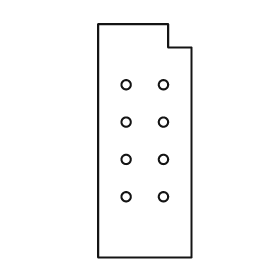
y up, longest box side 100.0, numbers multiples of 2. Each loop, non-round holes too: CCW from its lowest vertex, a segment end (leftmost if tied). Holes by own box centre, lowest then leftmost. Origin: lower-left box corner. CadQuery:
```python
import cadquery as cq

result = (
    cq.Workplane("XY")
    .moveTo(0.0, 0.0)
    .lineTo(40.0, 0.0)
    .lineTo(40.0, 90.0)
    .lineTo(30.0, 90.0)
    .lineTo(30.0, 100.0)
    .lineTo(0.0, 100.0)
    .close()
    .moveTo(12.0, 26.0)
    .circle(2.0)
    .moveTo(28.0, 26.0)
    .circle(2.0)
    .moveTo(12.0, 42.0)
    .circle(2.0)
    .moveTo(28.0, 42.0)
    .circle(2.0)
    .moveTo(12.0, 58.0)
    .circle(2.0)
    .moveTo(28.0, 58.0)
    .circle(2.0)
    .moveTo(12.0, 74.0)
    .circle(2.0)
    .moveTo(28.0, 74.0)
    .circle(2.0)
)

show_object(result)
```